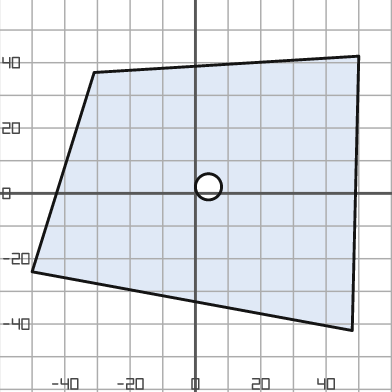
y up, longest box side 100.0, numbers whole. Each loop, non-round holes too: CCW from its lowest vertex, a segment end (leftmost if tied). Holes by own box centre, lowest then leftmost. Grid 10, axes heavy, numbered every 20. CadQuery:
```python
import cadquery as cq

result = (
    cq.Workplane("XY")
    .moveTo(48.0, -42.0)
    .lineTo(50.0, 42.0)
    .lineTo(-31.0, 37.0)
    .lineTo(-50.0, -24.0)
    .close()
    .moveTo(4.0, 2.0)
    .circle(4.0)
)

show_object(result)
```